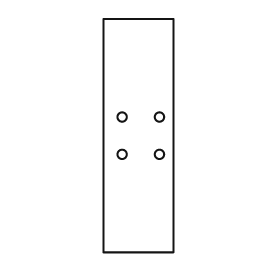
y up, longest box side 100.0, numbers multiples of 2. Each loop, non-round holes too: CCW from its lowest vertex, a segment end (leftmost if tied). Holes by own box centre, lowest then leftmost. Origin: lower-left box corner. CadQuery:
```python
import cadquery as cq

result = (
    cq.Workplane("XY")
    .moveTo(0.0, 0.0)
    .lineTo(30.0, 0.0)
    .lineTo(30.0, 100.0)
    .lineTo(0.0, 100.0)
    .close()
    .moveTo(8.0, 42.0)
    .circle(2.0)
    .moveTo(24.0, 42.0)
    .circle(2.0)
    .moveTo(8.0, 58.0)
    .circle(2.0)
    .moveTo(24.0, 58.0)
    .circle(2.0)
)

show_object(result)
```